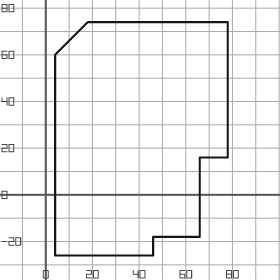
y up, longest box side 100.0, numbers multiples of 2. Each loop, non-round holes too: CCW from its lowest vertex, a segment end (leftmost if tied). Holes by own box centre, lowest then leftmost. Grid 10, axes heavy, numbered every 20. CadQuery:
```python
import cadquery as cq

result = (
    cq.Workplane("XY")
    .moveTo(4.0, -26.0)
    .lineTo(46.0, -26.0)
    .lineTo(46.0, -18.0)
    .lineTo(66.0, -18.0)
    .lineTo(66.0, 16.0)
    .lineTo(78.0, 16.0)
    .lineTo(78.0, 74.0)
    .lineTo(18.0, 74.0)
    .lineTo(4.0, 60.0)
    .close()
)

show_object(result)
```